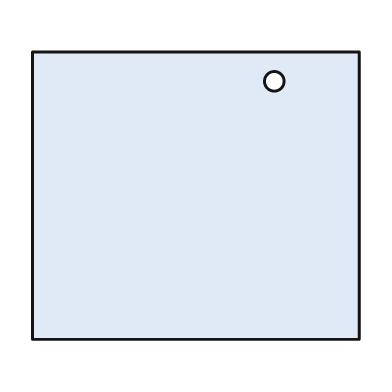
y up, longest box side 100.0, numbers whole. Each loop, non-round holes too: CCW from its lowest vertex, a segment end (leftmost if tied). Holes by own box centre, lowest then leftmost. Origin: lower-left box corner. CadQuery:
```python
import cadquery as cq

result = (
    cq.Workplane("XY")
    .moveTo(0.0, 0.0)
    .lineTo(100.0, 0.0)
    .lineTo(100.0, 88.0)
    .lineTo(0.0, 88.0)
    .close()
    .moveTo(74.0, 79.0)
    .circle(3.0)
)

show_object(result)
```